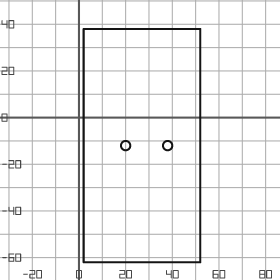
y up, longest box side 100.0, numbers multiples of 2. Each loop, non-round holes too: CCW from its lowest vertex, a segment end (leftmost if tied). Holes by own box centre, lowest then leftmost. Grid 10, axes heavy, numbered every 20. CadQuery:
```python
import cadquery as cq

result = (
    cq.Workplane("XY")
    .moveTo(2.0, -62.0)
    .lineTo(52.0, -62.0)
    .lineTo(52.0, 38.0)
    .lineTo(2.0, 38.0)
    .close()
    .moveTo(20.0, -12.0)
    .circle(2.0)
    .moveTo(38.0, -12.0)
    .circle(2.0)
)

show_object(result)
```